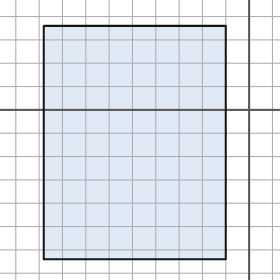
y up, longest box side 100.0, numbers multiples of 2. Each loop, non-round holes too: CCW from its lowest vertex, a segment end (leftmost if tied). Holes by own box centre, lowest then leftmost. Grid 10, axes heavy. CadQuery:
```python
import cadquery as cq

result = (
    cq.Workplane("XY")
    .moveTo(-88.0, -64.0)
    .lineTo(-10.0, -64.0)
    .lineTo(-10.0, 36.0)
    .lineTo(-88.0, 36.0)
    .close()
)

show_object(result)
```